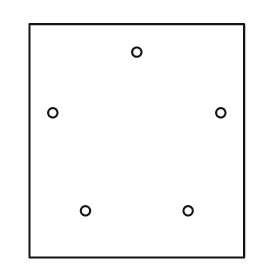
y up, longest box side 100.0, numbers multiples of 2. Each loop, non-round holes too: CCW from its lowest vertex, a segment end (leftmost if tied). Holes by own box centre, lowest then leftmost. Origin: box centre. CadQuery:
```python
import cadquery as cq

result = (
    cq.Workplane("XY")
    .moveTo(-46.0, -50.0)
    .lineTo(46.0, -50.0)
    .lineTo(46.0, 50.0)
    .lineTo(-46.0, 50.0)
    .close()
    .moveTo(-22.0, -30.0)
    .circle(2.0)
    .moveTo(22.0, -30.0)
    .circle(2.0)
    .moveTo(-36.0, 12.0)
    .circle(2.0)
    .moveTo(36.0, 12.0)
    .circle(2.0)
    .moveTo(0.0, 38.0)
    .circle(2.0)
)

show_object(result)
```